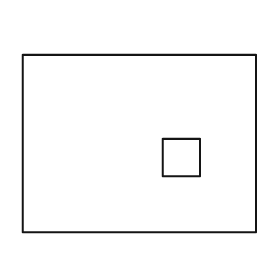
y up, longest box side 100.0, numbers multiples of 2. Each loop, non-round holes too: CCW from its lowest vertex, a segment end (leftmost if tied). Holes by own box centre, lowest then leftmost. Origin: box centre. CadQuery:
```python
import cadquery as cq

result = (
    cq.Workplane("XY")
    .moveTo(-50.0, -38.0)
    .lineTo(50.0, -38.0)
    .lineTo(50.0, 38.0)
    .lineTo(-50.0, 38.0)
    .close()
    .moveTo(10.0, -14.0)
    .lineTo(26.0, -14.0)
    .lineTo(26.0, 2.0)
    .lineTo(10.0, 2.0)
    .close()
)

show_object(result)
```